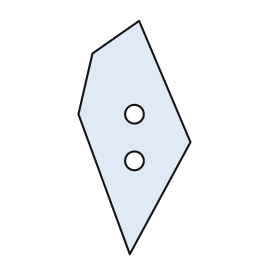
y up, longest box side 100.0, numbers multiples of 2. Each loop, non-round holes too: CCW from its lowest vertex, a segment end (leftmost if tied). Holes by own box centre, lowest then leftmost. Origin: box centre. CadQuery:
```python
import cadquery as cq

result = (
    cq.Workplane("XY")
    .moveTo(-2.0, -50.0)
    .lineTo(24.0, -2.0)
    .lineTo(2.0, 50.0)
    .lineTo(-18.0, 36.0)
    .lineTo(-24.0, 10.0)
    .close()
    .moveTo(0.0, -10.0)
    .circle(4.0)
    .moveTo(0.0, 10.0)
    .circle(4.0)
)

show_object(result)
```